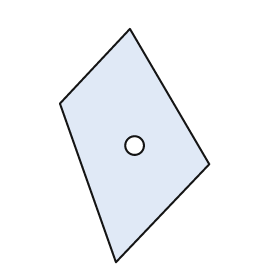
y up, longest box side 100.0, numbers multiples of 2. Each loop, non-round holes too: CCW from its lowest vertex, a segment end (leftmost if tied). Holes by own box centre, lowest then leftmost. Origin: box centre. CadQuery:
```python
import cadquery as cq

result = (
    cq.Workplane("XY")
    .moveTo(-8.0, -50.0)
    .lineTo(32.0, -8.0)
    .lineTo(-2.0, 50.0)
    .lineTo(-32.0, 18.0)
    .close()
    .moveTo(0.0, 0.0)
    .circle(4.0)
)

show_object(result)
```